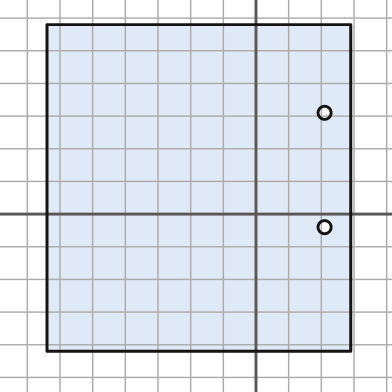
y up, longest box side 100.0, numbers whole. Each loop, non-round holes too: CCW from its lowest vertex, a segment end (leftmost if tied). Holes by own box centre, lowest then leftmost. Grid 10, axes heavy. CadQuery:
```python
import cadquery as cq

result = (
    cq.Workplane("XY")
    .moveTo(-64.0, -42.0)
    .lineTo(29.0, -42.0)
    .lineTo(29.0, 58.0)
    .lineTo(-64.0, 58.0)
    .close()
    .moveTo(21.0, -4.0)
    .circle(2.0)
    .moveTo(21.0, 31.0)
    .circle(2.0)
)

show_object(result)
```